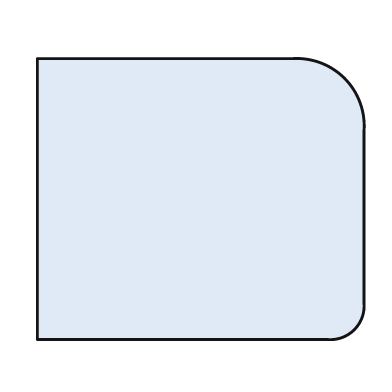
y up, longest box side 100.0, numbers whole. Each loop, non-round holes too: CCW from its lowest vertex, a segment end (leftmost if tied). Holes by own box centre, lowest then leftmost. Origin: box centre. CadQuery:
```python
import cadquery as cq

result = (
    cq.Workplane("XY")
    .moveTo(-50.0, -43.0)
    .lineTo(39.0, -43.0)
    .threePointArc((47.0, -40.0), (50.0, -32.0))
    .lineTo(50.0, 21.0)
    .threePointArc((44.0, 37.0), (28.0, 43.0))
    .lineTo(-50.0, 43.0)
    .close()
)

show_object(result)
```